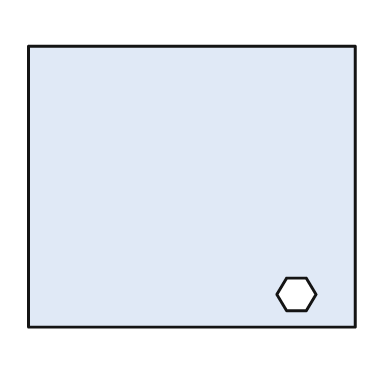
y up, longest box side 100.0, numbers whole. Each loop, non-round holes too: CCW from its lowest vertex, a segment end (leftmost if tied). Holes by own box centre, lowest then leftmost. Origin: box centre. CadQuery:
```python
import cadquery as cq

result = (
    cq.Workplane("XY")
    .moveTo(-50.0, -43.0)
    .lineTo(50.0, -43.0)
    .lineTo(50.0, 43.0)
    .lineTo(-50.0, 43.0)
    .close()
    .moveTo(29.0, -38.0)
    .lineTo(35.0, -38.0)
    .lineTo(38.0, -33.0)
    .lineTo(35.0, -28.0)
    .lineTo(29.0, -28.0)
    .lineTo(26.0, -33.0)
    .close()
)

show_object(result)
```